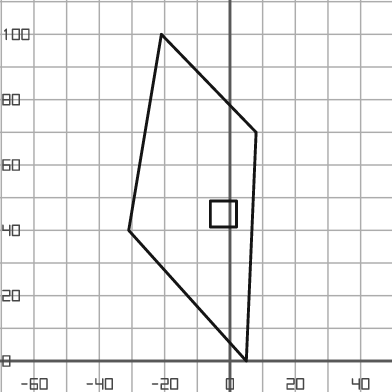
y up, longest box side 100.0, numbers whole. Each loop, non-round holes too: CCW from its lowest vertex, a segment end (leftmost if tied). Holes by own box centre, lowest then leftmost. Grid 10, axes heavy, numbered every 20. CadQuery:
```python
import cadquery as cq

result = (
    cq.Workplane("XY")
    .moveTo(5.0, 0.0)
    .lineTo(8.0, 70.0)
    .lineTo(-21.0, 100.0)
    .lineTo(-31.0, 40.0)
    .close()
    .moveTo(-6.0, 41.0)
    .lineTo(2.0, 41.0)
    .lineTo(2.0, 49.0)
    .lineTo(-6.0, 49.0)
    .close()
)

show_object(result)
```